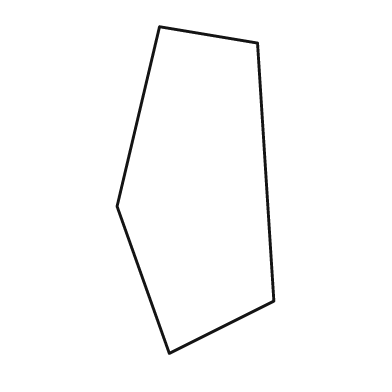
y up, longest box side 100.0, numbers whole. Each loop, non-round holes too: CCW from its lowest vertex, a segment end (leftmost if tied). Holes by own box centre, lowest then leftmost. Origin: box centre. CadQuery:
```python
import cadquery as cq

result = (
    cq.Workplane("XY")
    .moveTo(-8.0, -50.0)
    .lineTo(24.0, -34.0)
    .lineTo(19.0, 45.0)
    .lineTo(-11.0, 50.0)
    .lineTo(-24.0, -5.0)
    .close()
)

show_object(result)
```